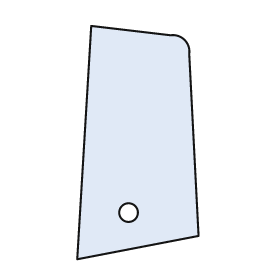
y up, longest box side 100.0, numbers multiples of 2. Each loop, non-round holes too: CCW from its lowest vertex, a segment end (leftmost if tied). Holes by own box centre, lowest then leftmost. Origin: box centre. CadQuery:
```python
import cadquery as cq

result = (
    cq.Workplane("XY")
    .moveTo(-26.0, -50.0)
    .lineTo(26.0, -40.0)
    .lineTo(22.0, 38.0)
    .threePointArc((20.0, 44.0), (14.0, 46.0))
    .lineTo(-20.0, 50.0)
    .close()
    .moveTo(-4.0, -30.0)
    .circle(4.0)
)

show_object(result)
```